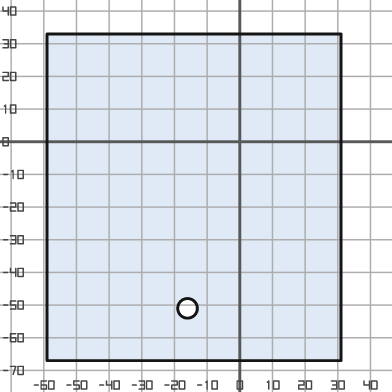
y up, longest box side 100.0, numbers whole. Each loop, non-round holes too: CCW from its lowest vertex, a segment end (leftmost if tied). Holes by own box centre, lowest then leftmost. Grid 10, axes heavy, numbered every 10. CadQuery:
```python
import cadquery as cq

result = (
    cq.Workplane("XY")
    .moveTo(-59.0, -67.0)
    .lineTo(31.0, -67.0)
    .lineTo(31.0, 33.0)
    .lineTo(-59.0, 33.0)
    .close()
    .moveTo(-16.0, -51.0)
    .circle(3.0)
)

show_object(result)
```